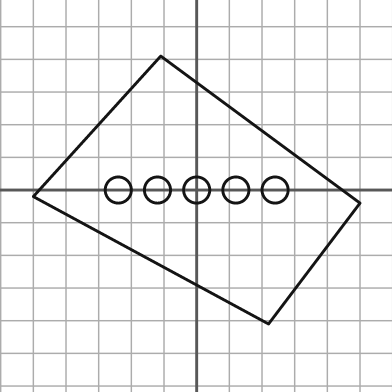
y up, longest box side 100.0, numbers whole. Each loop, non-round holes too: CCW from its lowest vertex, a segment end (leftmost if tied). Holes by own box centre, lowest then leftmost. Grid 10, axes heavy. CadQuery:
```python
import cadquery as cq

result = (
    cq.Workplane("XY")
    .moveTo(22.0, -41.0)
    .lineTo(50.0, -4.0)
    .lineTo(-11.0, 41.0)
    .lineTo(-50.0, -2.0)
    .close()
    .moveTo(-24.0, 0.0)
    .circle(4.0)
    .moveTo(-12.0, 0.0)
    .circle(4.0)
    .moveTo(0.0, 0.0)
    .circle(4.0)
    .moveTo(12.0, 0.0)
    .circle(4.0)
    .moveTo(24.0, 0.0)
    .circle(4.0)
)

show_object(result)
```